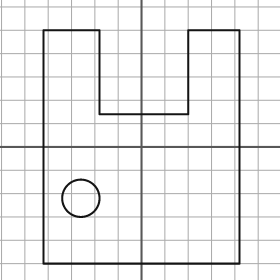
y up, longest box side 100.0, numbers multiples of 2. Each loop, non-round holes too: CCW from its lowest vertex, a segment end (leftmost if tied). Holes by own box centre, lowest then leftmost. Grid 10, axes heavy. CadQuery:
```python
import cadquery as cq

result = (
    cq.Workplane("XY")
    .moveTo(-42.0, -50.0)
    .lineTo(42.0, -50.0)
    .lineTo(42.0, 50.0)
    .lineTo(20.0, 50.0)
    .lineTo(20.0, 14.0)
    .lineTo(-18.0, 14.0)
    .lineTo(-18.0, 50.0)
    .lineTo(-42.0, 50.0)
    .close()
    .moveTo(-26.0, -22.0)
    .circle(8.0)
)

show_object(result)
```